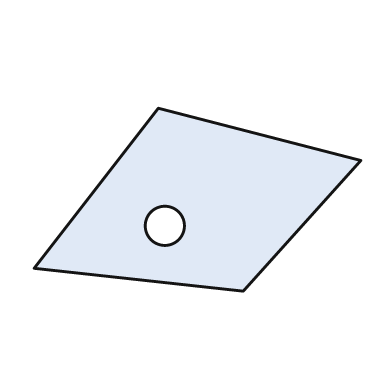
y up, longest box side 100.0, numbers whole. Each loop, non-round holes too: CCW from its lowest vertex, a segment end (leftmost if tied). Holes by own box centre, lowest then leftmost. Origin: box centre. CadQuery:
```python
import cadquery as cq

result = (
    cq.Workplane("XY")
    .moveTo(14.0, -28.0)
    .lineTo(50.0, 12.0)
    .lineTo(-12.0, 28.0)
    .lineTo(-50.0, -21.0)
    .close()
    .moveTo(-10.0, -8.0)
    .circle(6.0)
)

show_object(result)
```